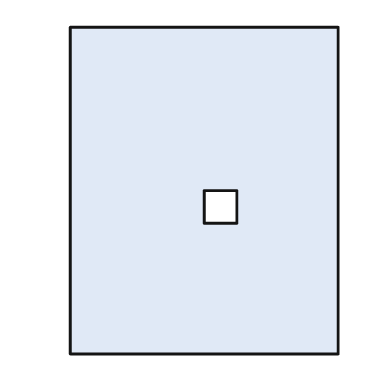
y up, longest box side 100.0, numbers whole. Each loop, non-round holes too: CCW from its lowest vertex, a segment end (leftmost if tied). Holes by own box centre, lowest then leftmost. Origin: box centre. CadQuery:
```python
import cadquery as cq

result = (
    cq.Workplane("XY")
    .moveTo(-41.0, -50.0)
    .lineTo(41.0, -50.0)
    .lineTo(41.0, 50.0)
    .lineTo(-41.0, 50.0)
    .close()
    .moveTo(0.0, -10.0)
    .lineTo(10.0, -10.0)
    .lineTo(10.0, 0.0)
    .lineTo(0.0, 0.0)
    .close()
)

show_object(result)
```